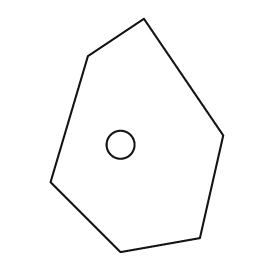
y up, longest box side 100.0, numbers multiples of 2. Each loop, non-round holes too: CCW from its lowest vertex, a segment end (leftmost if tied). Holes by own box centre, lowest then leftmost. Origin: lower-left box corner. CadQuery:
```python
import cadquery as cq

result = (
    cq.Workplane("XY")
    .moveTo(30.0, 0.0)
    .lineTo(64.0, 6.0)
    .lineTo(74.0, 50.0)
    .lineTo(40.0, 100.0)
    .lineTo(16.0, 84.0)
    .lineTo(0.0, 30.0)
    .close()
    .moveTo(30.0, 46.0)
    .circle(6.0)
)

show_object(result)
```